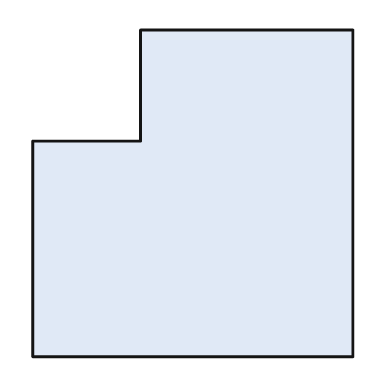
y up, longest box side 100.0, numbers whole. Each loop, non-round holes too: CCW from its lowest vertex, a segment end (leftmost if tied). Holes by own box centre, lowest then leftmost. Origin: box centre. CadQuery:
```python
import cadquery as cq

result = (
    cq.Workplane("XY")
    .moveTo(-49.0, -50.0)
    .lineTo(49.0, -50.0)
    .lineTo(49.0, 50.0)
    .lineTo(-16.0, 50.0)
    .lineTo(-16.0, 16.0)
    .lineTo(-49.0, 16.0)
    .close()
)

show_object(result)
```